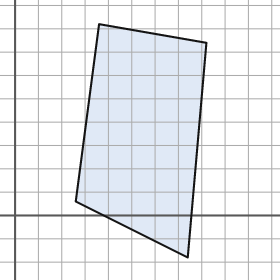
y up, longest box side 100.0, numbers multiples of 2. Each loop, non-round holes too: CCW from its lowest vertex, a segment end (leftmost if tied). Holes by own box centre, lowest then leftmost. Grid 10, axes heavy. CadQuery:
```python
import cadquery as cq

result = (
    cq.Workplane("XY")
    .moveTo(74.0, -18.0)
    .lineTo(82.0, 74.0)
    .lineTo(36.0, 82.0)
    .lineTo(26.0, 6.0)
    .close()
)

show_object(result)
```